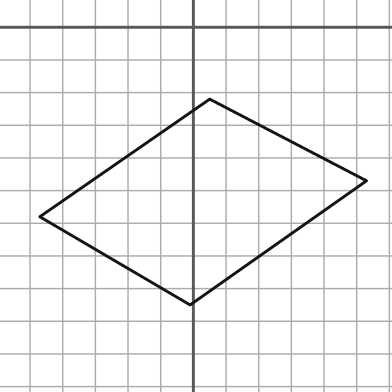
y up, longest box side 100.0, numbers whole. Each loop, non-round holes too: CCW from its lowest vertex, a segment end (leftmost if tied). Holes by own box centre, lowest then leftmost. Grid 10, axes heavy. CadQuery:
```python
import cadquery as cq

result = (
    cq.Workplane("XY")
    .moveTo(-1.0, -85.0)
    .lineTo(53.0, -47.0)
    .lineTo(5.0, -22.0)
    .lineTo(-47.0, -58.0)
    .close()
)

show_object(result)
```